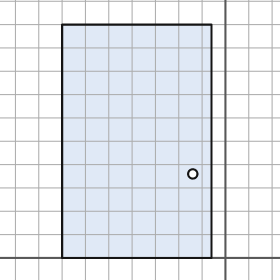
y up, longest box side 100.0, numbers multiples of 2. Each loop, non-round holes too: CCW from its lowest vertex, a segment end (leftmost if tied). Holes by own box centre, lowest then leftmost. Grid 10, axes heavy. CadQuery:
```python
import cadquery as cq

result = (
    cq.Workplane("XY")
    .moveTo(-70.0, 0.0)
    .lineTo(-6.0, 0.0)
    .lineTo(-6.0, 100.0)
    .lineTo(-70.0, 100.0)
    .close()
    .moveTo(-14.0, 36.0)
    .circle(2.0)
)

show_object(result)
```